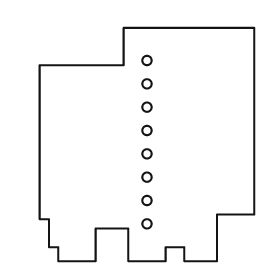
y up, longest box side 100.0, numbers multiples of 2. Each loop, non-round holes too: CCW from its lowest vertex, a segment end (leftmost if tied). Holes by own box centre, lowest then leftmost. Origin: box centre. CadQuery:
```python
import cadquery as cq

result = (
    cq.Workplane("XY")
    .moveTo(-38.0, -50.0)
    .lineTo(-22.0, -50.0)
    .lineTo(-22.0, -36.0)
    .lineTo(-8.0, -36.0)
    .lineTo(-8.0, -50.0)
    .lineTo(8.0, -50.0)
    .lineTo(8.0, -44.0)
    .lineTo(16.0, -44.0)
    .lineTo(16.0, -50.0)
    .lineTo(30.0, -50.0)
    .lineTo(30.0, -30.0)
    .lineTo(46.0, -30.0)
    .lineTo(46.0, 50.0)
    .lineTo(-10.0, 50.0)
    .lineTo(-10.0, 34.0)
    .lineTo(-46.0, 34.0)
    .lineTo(-46.0, -32.0)
    .lineTo(-42.0, -32.0)
    .lineTo(-42.0, -44.0)
    .lineTo(-38.0, -44.0)
    .close()
    .moveTo(0.0, -34.0)
    .circle(2.0)
    .moveTo(0.0, -24.0)
    .circle(2.0)
    .moveTo(0.0, -14.0)
    .circle(2.0)
    .moveTo(0.0, -4.0)
    .circle(2.0)
    .moveTo(0.0, 6.0)
    .circle(2.0)
    .moveTo(0.0, 16.0)
    .circle(2.0)
    .moveTo(0.0, 26.0)
    .circle(2.0)
    .moveTo(0.0, 36.0)
    .circle(2.0)
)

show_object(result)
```